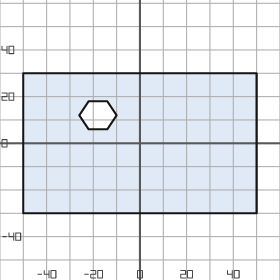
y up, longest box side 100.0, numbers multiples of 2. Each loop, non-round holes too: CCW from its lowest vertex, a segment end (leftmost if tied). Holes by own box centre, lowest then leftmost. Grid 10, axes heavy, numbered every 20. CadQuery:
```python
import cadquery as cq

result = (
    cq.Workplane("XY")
    .moveTo(-50.0, -30.0)
    .lineTo(50.0, -30.0)
    .lineTo(50.0, 30.0)
    .lineTo(-50.0, 30.0)
    .close()
    .moveTo(-22.0, 6.0)
    .lineTo(-14.0, 6.0)
    .lineTo(-10.0, 12.0)
    .lineTo(-14.0, 18.0)
    .lineTo(-22.0, 18.0)
    .lineTo(-26.0, 12.0)
    .close()
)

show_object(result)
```